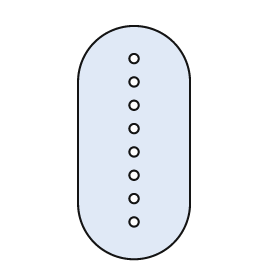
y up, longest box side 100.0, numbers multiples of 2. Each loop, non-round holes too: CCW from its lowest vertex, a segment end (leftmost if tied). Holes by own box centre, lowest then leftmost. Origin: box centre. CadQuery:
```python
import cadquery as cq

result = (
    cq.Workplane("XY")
    .moveTo(-24.0, -26.0)
    .threePointArc((0.0, -50.0), (24.0, -26.0))
    .lineTo(24.0, 26.0)
    .threePointArc((0.0, 50.0), (-24.0, 26.0))
    .close()
    .moveTo(0.0, -34.0)
    .circle(2.0)
    .moveTo(0.0, -24.0)
    .circle(2.0)
    .moveTo(0.0, -14.0)
    .circle(2.0)
    .moveTo(0.0, -4.0)
    .circle(2.0)
    .moveTo(0.0, 6.0)
    .circle(2.0)
    .moveTo(0.0, 16.0)
    .circle(2.0)
    .moveTo(0.0, 26.0)
    .circle(2.0)
    .moveTo(0.0, 36.0)
    .circle(2.0)
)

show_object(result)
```